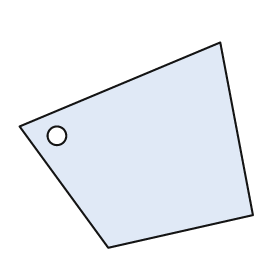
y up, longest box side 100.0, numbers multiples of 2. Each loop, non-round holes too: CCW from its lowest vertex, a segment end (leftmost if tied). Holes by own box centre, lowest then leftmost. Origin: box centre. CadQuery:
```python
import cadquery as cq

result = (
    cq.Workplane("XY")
    .moveTo(-12.0, -44.0)
    .lineTo(50.0, -30.0)
    .lineTo(36.0, 44.0)
    .lineTo(-50.0, 8.0)
    .close()
    .moveTo(-34.0, 4.0)
    .circle(4.0)
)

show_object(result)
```